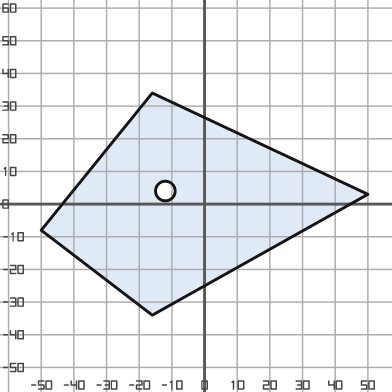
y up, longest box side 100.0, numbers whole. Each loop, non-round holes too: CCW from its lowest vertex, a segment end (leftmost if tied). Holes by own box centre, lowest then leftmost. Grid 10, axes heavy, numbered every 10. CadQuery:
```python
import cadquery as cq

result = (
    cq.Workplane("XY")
    .moveTo(-16.0, -34.0)
    .lineTo(50.0, 3.0)
    .lineTo(-16.0, 34.0)
    .lineTo(-50.0, -8.0)
    .close()
    .moveTo(-12.0, 4.0)
    .circle(3.0)
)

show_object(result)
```